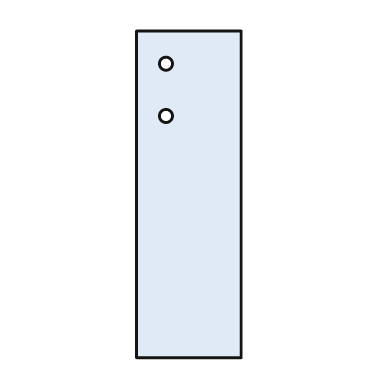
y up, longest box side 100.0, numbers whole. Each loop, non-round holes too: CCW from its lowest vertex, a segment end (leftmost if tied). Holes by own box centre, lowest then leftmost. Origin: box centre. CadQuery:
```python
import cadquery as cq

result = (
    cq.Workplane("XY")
    .moveTo(-16.0, -50.0)
    .lineTo(16.0, -50.0)
    .lineTo(16.0, 50.0)
    .lineTo(-16.0, 50.0)
    .close()
    .moveTo(-7.0, 24.0)
    .circle(2.0)
    .moveTo(-7.0, 40.0)
    .circle(2.0)
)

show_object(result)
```